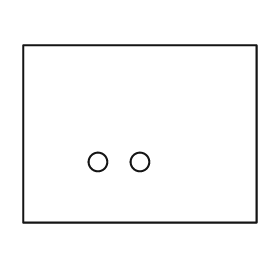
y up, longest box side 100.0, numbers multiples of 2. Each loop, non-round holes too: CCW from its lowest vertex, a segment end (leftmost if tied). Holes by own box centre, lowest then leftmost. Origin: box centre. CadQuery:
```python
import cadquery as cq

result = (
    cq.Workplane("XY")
    .moveTo(-50.0, -38.0)
    .lineTo(50.0, -38.0)
    .lineTo(50.0, 38.0)
    .lineTo(-50.0, 38.0)
    .close()
    .moveTo(-18.0, -12.0)
    .circle(4.0)
    .moveTo(0.0, -12.0)
    .circle(4.0)
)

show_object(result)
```